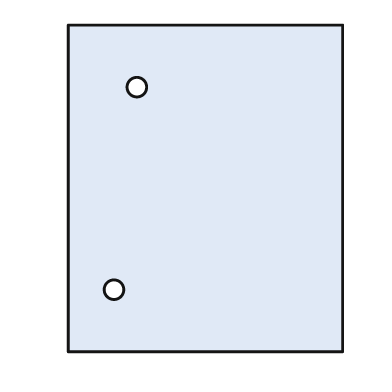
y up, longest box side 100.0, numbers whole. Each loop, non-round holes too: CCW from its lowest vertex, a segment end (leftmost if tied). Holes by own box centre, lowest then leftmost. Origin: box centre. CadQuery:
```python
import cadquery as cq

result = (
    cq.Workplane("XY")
    .moveTo(-42.0, -50.0)
    .lineTo(42.0, -50.0)
    .lineTo(42.0, 50.0)
    .lineTo(-42.0, 50.0)
    .close()
    .moveTo(-28.0, -31.0)
    .circle(3.0)
    .moveTo(-21.0, 31.0)
    .circle(3.0)
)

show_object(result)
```